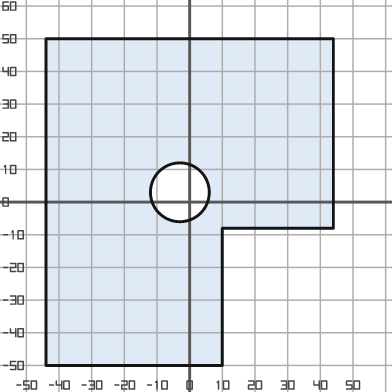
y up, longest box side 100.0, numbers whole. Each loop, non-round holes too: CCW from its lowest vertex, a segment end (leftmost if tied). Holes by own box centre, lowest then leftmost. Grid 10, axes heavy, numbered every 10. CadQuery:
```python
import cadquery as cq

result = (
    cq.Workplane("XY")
    .moveTo(-44.0, -50.0)
    .lineTo(10.0, -50.0)
    .lineTo(10.0, -8.0)
    .lineTo(44.0, -8.0)
    .lineTo(44.0, 50.0)
    .lineTo(-44.0, 50.0)
    .close()
    .moveTo(-3.0, 3.0)
    .circle(9.0)
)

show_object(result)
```